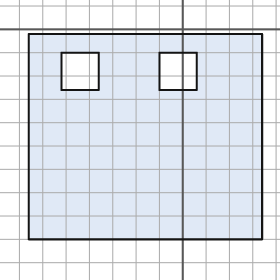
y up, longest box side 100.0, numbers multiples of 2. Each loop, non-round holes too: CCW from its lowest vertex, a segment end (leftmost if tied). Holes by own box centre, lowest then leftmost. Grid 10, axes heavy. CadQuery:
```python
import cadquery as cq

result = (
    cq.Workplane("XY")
    .moveTo(-66.0, -90.0)
    .lineTo(34.0, -90.0)
    .lineTo(34.0, -2.0)
    .lineTo(-66.0, -2.0)
    .close()
    .moveTo(-52.0, -26.0)
    .lineTo(-36.0, -26.0)
    .lineTo(-36.0, -10.0)
    .lineTo(-52.0, -10.0)
    .close()
    .moveTo(-10.0, -26.0)
    .lineTo(6.0, -26.0)
    .lineTo(6.0, -10.0)
    .lineTo(-10.0, -10.0)
    .close()
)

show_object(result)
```